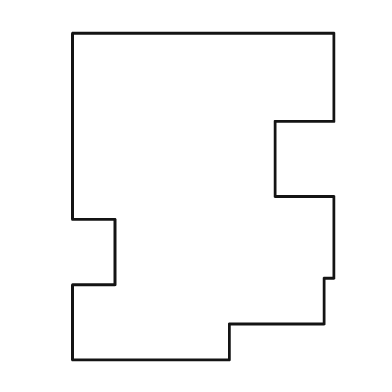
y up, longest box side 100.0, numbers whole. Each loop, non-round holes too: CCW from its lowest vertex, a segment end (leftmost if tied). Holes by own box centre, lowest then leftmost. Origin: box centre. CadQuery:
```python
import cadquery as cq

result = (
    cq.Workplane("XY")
    .moveTo(-40.0, -50.0)
    .lineTo(8.0, -50.0)
    .lineTo(8.0, -39.0)
    .lineTo(37.0, -39.0)
    .lineTo(37.0, -25.0)
    .lineTo(40.0, -25.0)
    .lineTo(40.0, 0.0)
    .lineTo(22.0, 0.0)
    .lineTo(22.0, 23.0)
    .lineTo(40.0, 23.0)
    .lineTo(40.0, 50.0)
    .lineTo(-40.0, 50.0)
    .lineTo(-40.0, -7.0)
    .lineTo(-27.0, -7.0)
    .lineTo(-27.0, -27.0)
    .lineTo(-40.0, -27.0)
    .close()
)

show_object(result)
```